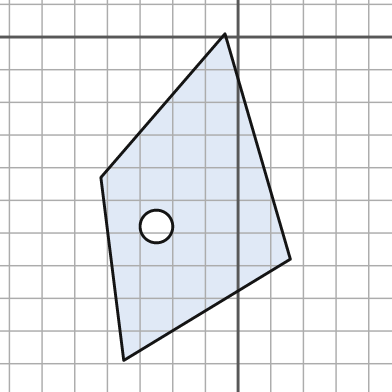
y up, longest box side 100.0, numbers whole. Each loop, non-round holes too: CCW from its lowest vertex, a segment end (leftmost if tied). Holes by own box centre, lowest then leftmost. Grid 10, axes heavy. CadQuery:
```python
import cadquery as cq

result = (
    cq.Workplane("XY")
    .moveTo(-35.0, -99.0)
    .lineTo(16.0, -68.0)
    .lineTo(-4.0, 1.0)
    .lineTo(-42.0, -43.0)
    .close()
    .moveTo(-25.0, -58.0)
    .circle(5.0)
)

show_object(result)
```